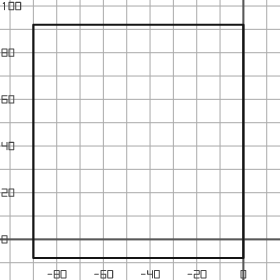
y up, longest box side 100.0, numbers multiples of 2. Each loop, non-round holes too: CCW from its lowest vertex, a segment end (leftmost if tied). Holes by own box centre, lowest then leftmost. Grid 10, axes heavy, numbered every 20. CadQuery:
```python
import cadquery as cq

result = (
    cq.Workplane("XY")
    .moveTo(-90.0, -8.0)
    .lineTo(0.0, -8.0)
    .lineTo(0.0, 92.0)
    .lineTo(-90.0, 92.0)
    .close()
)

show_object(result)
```